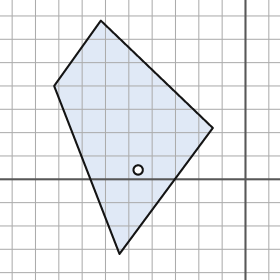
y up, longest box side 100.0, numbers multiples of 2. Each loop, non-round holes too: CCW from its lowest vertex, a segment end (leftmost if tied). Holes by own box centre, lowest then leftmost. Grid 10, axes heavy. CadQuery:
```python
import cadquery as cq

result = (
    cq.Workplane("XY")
    .moveTo(-54.0, -32.0)
    .lineTo(-14.0, 22.0)
    .lineTo(-62.0, 68.0)
    .lineTo(-82.0, 40.0)
    .close()
    .moveTo(-46.0, 4.0)
    .circle(2.0)
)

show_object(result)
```